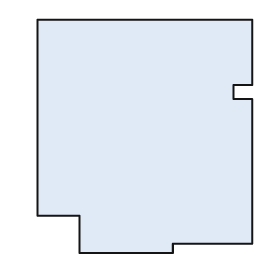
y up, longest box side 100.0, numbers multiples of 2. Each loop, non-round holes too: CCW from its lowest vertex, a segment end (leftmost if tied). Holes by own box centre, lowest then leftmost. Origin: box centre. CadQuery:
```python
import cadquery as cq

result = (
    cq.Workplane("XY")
    .moveTo(-28.0, -50.0)
    .lineTo(12.0, -50.0)
    .lineTo(12.0, -46.0)
    .lineTo(46.0, -46.0)
    .lineTo(46.0, 16.0)
    .lineTo(38.0, 16.0)
    .lineTo(38.0, 22.0)
    .lineTo(46.0, 22.0)
    .lineTo(46.0, 50.0)
    .lineTo(-46.0, 50.0)
    .lineTo(-46.0, -34.0)
    .lineTo(-28.0, -34.0)
    .close()
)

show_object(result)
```